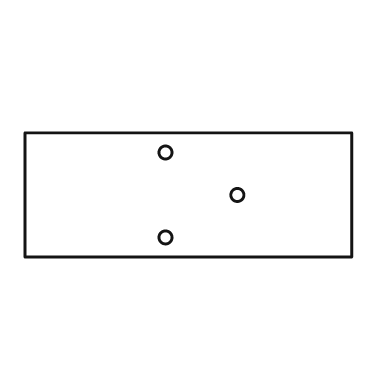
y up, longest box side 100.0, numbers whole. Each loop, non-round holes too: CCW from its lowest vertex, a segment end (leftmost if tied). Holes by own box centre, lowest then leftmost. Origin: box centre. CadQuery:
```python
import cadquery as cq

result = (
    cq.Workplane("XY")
    .moveTo(-50.0, -19.0)
    .lineTo(50.0, -19.0)
    .lineTo(50.0, 19.0)
    .lineTo(-50.0, 19.0)
    .close()
    .moveTo(-7.0, -13.0)
    .circle(2.0)
    .moveTo(15.0, 0.0)
    .circle(2.0)
    .moveTo(-7.0, 13.0)
    .circle(2.0)
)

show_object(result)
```